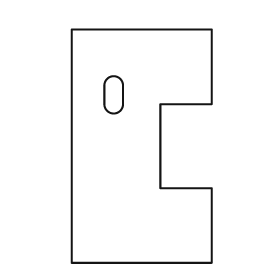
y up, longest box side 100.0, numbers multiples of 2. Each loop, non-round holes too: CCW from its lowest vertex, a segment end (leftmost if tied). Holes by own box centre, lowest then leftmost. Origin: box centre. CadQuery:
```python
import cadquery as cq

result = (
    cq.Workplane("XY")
    .moveTo(-30.0, -50.0)
    .lineTo(30.0, -50.0)
    .lineTo(30.0, -18.0)
    .lineTo(8.0, -18.0)
    .lineTo(8.0, 18.0)
    .lineTo(30.0, 18.0)
    .lineTo(30.0, 50.0)
    .lineTo(-30.0, 50.0)
    .close()
    .moveTo(-16.0, 18.0)
    .threePointArc((-12.0, 14.0), (-8.0, 18.0))
    .lineTo(-8.0, 26.0)
    .threePointArc((-12.0, 30.0), (-16.0, 26.0))
    .close()
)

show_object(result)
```